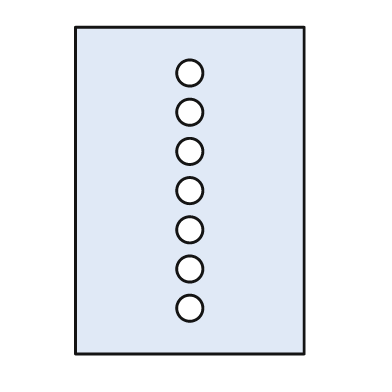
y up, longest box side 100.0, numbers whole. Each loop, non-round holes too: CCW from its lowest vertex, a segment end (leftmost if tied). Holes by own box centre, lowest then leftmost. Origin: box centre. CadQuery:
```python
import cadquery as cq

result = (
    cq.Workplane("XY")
    .moveTo(-35.0, -50.0)
    .lineTo(35.0, -50.0)
    .lineTo(35.0, 50.0)
    .lineTo(-35.0, 50.0)
    .close()
    .moveTo(0.0, -36.0)
    .circle(4.0)
    .moveTo(0.0, -24.0)
    .circle(4.0)
    .moveTo(0.0, -12.0)
    .circle(4.0)
    .moveTo(0.0, 0.0)
    .circle(4.0)
    .moveTo(0.0, 12.0)
    .circle(4.0)
    .moveTo(0.0, 24.0)
    .circle(4.0)
    .moveTo(0.0, 36.0)
    .circle(4.0)
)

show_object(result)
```